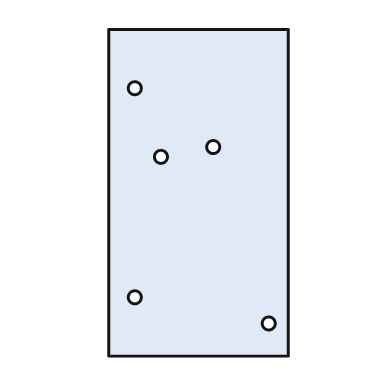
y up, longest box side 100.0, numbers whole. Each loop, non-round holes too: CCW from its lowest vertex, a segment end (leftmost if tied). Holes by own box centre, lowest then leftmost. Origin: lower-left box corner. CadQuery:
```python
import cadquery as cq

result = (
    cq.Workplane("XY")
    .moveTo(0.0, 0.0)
    .lineTo(55.0, 0.0)
    .lineTo(55.0, 100.0)
    .lineTo(0.0, 100.0)
    .close()
    .moveTo(49.0, 10.0)
    .circle(2.0)
    .moveTo(8.0, 18.0)
    .circle(2.0)
    .moveTo(16.0, 61.0)
    .circle(2.0)
    .moveTo(32.0, 64.0)
    .circle(2.0)
    .moveTo(8.0, 82.0)
    .circle(2.0)
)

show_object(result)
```